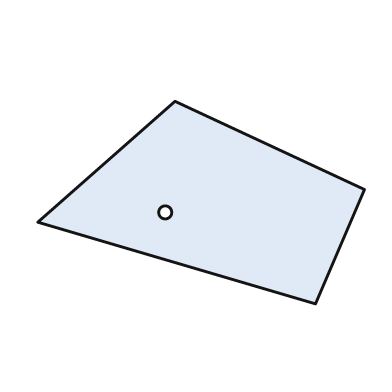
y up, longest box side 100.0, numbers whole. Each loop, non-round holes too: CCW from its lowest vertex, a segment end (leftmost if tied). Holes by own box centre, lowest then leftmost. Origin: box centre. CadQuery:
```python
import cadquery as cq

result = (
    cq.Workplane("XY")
    .moveTo(35.0, -31.0)
    .lineTo(50.0, 4.0)
    .lineTo(-8.0, 31.0)
    .lineTo(-50.0, -6.0)
    .close()
    .moveTo(-11.0, -3.0)
    .circle(2.0)
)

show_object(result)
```